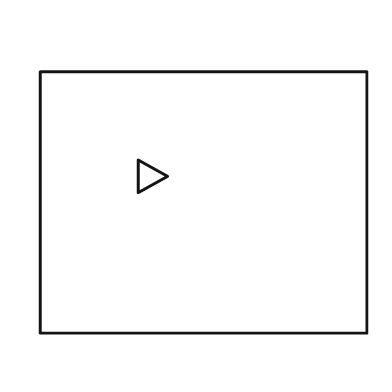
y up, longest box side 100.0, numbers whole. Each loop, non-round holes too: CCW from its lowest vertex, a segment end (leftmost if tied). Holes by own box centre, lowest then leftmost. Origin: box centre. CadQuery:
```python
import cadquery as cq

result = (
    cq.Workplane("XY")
    .moveTo(-50.0, -40.0)
    .lineTo(50.0, -40.0)
    .lineTo(50.0, 40.0)
    .lineTo(-50.0, 40.0)
    .close()
    .moveTo(-20.0, 3.0)
    .lineTo(-11.0, 8.0)
    .lineTo(-20.0, 13.0)
    .close()
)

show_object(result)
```